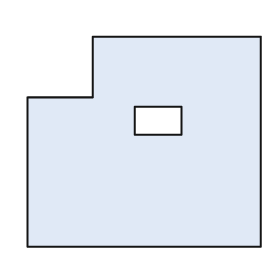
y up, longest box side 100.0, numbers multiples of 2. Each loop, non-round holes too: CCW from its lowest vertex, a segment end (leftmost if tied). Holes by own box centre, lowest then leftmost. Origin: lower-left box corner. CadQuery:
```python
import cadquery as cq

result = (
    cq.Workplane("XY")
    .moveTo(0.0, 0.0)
    .lineTo(100.0, 0.0)
    .lineTo(100.0, 90.0)
    .lineTo(28.0, 90.0)
    .lineTo(28.0, 64.0)
    .lineTo(0.0, 64.0)
    .close()
    .moveTo(46.0, 48.0)
    .lineTo(66.0, 48.0)
    .lineTo(66.0, 60.0)
    .lineTo(46.0, 60.0)
    .close()
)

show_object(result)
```